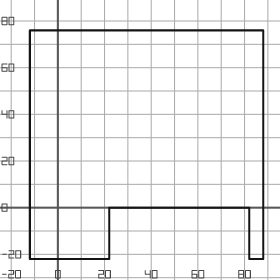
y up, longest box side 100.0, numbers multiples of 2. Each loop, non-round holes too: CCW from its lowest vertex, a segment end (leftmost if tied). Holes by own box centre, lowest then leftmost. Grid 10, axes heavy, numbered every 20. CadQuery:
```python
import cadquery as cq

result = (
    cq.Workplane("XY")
    .moveTo(-12.0, -22.0)
    .lineTo(22.0, -22.0)
    .lineTo(22.0, 0.0)
    .lineTo(82.0, 0.0)
    .lineTo(82.0, -22.0)
    .lineTo(88.0, -22.0)
    .lineTo(88.0, 76.0)
    .lineTo(-12.0, 76.0)
    .close()
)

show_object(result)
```